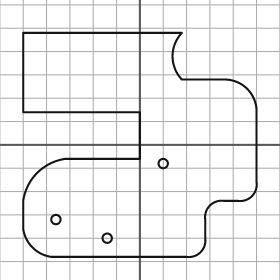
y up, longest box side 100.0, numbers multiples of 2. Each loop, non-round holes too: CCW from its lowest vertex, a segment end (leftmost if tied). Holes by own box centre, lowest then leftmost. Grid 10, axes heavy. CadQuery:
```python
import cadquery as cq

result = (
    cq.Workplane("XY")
    .moveTo(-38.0, -48.0)
    .lineTo(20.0, -48.0)
    .threePointArc((26.0, -46.0), (28.0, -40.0))
    .lineTo(28.0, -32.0)
    .threePointArc((30.0, -26.0), (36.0, -24.0))
    .lineTo(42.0, -24.0)
    .threePointArc((48.0, -22.0), (50.0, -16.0))
    .lineTo(50.0, 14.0)
    .threePointArc((46.0, 24.0), (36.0, 28.0))
    .lineTo(18.0, 28.0)
    .threePointArc((14.0, 38.0), (18.0, 48.0))
    .lineTo(-50.0, 48.0)
    .lineTo(-50.0, 14.0)
    .lineTo(0.0, 14.0)
    .lineTo(0.0, -6.0)
    .lineTo(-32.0, -6.0)
    .threePointArc((-44.0, -12.0), (-50.0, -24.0))
    .lineTo(-50.0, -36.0)
    .threePointArc((-46.0, -44.0), (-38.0, -48.0))
    .close()
    .moveTo(-14.0, -40.0)
    .circle(2.0)
    .moveTo(-36.0, -32.0)
    .circle(2.0)
    .moveTo(10.0, -8.0)
    .circle(2.0)
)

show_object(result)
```